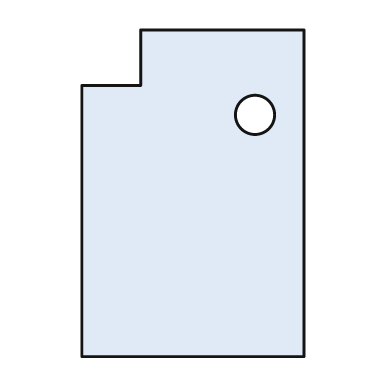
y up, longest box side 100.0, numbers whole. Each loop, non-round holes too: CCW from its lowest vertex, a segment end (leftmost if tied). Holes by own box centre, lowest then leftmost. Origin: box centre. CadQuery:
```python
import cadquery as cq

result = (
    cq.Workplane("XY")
    .moveTo(-34.0, -50.0)
    .lineTo(34.0, -50.0)
    .lineTo(34.0, 50.0)
    .lineTo(-16.0, 50.0)
    .lineTo(-16.0, 33.0)
    .lineTo(-34.0, 33.0)
    .close()
    .moveTo(19.0, 24.0)
    .circle(6.0)
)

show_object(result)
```